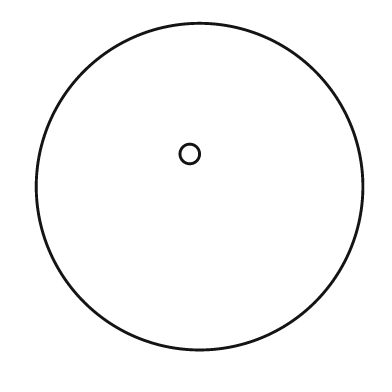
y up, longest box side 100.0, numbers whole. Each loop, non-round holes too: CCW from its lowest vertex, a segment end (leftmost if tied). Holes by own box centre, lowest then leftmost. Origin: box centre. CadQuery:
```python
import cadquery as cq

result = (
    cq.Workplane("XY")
    .moveTo(0.0, 0.0)
    .circle(50.0)
    .moveTo(-3.0, 10.0)
    .circle(3.0)
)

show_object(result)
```